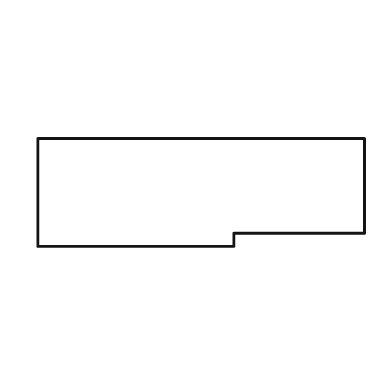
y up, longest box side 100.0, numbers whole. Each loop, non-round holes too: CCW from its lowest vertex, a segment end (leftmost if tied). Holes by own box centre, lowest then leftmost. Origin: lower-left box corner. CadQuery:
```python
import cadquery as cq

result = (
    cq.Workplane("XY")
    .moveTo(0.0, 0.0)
    .lineTo(60.0, 0.0)
    .lineTo(60.0, 4.0)
    .lineTo(100.0, 4.0)
    .lineTo(100.0, 33.0)
    .lineTo(0.0, 33.0)
    .close()
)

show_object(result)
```